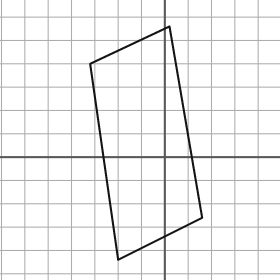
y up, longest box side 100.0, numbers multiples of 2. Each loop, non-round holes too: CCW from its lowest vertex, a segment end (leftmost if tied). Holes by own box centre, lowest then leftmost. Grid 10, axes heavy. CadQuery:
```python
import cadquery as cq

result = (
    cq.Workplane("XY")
    .moveTo(-20.0, -44.0)
    .lineTo(16.0, -26.0)
    .lineTo(2.0, 56.0)
    .lineTo(-32.0, 40.0)
    .close()
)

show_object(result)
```